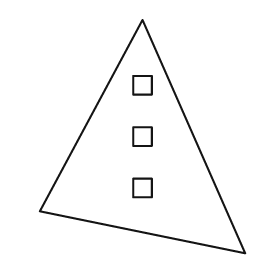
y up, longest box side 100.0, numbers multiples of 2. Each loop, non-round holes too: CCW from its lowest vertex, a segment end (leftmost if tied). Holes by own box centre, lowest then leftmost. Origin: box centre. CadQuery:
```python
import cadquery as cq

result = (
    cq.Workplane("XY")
    .moveTo(44.0, -50.0)
    .lineTo(0.0, 50.0)
    .lineTo(-44.0, -32.0)
    .close()
    .moveTo(-4.0, -26.0)
    .lineTo(4.0, -26.0)
    .lineTo(4.0, -18.0)
    .lineTo(-4.0, -18.0)
    .close()
    .moveTo(-4.0, -4.0)
    .lineTo(4.0, -4.0)
    .lineTo(4.0, 4.0)
    .lineTo(-4.0, 4.0)
    .close()
    .moveTo(-4.0, 18.0)
    .lineTo(4.0, 18.0)
    .lineTo(4.0, 26.0)
    .lineTo(-4.0, 26.0)
    .close()
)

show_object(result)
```